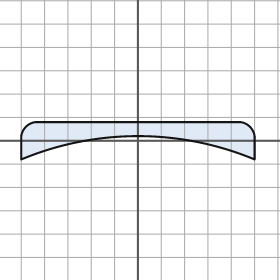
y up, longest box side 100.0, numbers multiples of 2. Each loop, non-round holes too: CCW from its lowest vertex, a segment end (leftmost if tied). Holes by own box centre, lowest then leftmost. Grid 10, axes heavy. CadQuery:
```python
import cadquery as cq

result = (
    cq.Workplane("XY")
    .moveTo(-50.0, -8.0)
    .threePointArc((0.0, 2.0), (50.0, -8.0))
    .lineTo(50.0, 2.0)
    .threePointArc((48.0, 6.0), (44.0, 8.0))
    .lineTo(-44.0, 8.0)
    .threePointArc((-48.0, 6.0), (-50.0, 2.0))
    .close()
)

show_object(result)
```